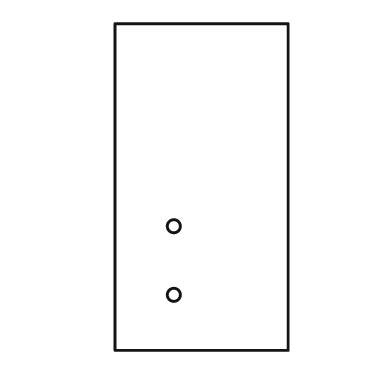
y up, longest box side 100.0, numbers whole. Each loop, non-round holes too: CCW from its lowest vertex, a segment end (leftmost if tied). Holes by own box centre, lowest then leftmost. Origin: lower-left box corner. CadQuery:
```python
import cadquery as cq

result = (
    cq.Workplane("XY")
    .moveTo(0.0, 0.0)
    .lineTo(53.0, 0.0)
    .lineTo(53.0, 100.0)
    .lineTo(0.0, 100.0)
    .close()
    .moveTo(18.0, 17.0)
    .circle(2.0)
    .moveTo(18.0, 38.0)
    .circle(2.0)
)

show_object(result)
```